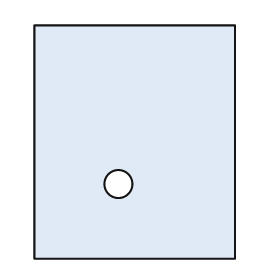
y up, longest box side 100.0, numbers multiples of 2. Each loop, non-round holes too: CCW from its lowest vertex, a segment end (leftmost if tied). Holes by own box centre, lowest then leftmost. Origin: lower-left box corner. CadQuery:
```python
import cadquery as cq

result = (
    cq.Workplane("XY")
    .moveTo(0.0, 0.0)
    .lineTo(86.0, 0.0)
    .lineTo(86.0, 100.0)
    .lineTo(0.0, 100.0)
    .close()
    .moveTo(36.0, 32.0)
    .circle(6.0)
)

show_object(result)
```